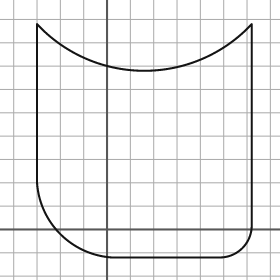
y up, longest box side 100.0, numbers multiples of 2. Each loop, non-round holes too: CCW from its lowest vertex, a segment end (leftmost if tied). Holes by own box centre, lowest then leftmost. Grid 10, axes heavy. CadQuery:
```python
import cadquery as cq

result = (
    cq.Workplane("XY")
    .moveTo(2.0, -12.0)
    .lineTo(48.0, -12.0)
    .threePointArc((58.0, -8.0), (62.0, 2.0))
    .lineTo(62.0, 88.0)
    .threePointArc((16.0, 68.0), (-30.0, 88.0))
    .lineTo(-30.0, 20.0)
    .threePointArc((-20.0, -2.0), (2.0, -12.0))
    .close()
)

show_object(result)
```